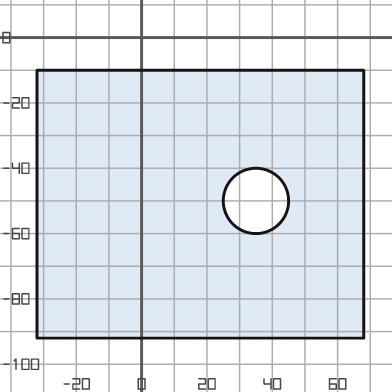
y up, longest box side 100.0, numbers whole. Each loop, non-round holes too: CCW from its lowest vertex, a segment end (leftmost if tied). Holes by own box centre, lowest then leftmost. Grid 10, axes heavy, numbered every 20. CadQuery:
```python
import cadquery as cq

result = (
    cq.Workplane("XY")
    .moveTo(-32.0, -92.0)
    .lineTo(68.0, -92.0)
    .lineTo(68.0, -10.0)
    .lineTo(-32.0, -10.0)
    .close()
    .moveTo(35.0, -50.0)
    .circle(10.0)
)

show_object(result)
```